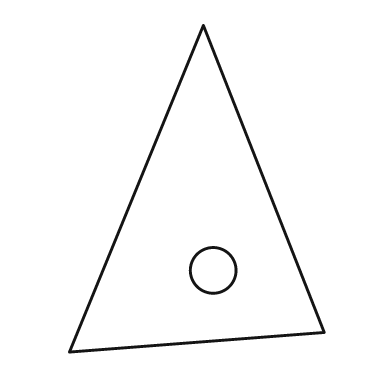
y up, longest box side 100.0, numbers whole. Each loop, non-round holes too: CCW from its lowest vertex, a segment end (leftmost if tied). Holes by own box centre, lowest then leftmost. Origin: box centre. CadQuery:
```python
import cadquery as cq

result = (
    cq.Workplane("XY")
    .moveTo(-39.0, -50.0)
    .lineTo(39.0, -44.0)
    .lineTo(2.0, 50.0)
    .close()
    .moveTo(5.0, -25.0)
    .circle(7.0)
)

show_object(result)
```